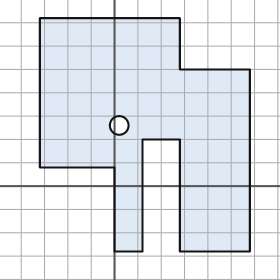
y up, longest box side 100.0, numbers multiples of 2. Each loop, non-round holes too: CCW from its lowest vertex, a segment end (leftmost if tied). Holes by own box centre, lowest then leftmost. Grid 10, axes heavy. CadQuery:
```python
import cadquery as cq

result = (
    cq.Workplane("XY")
    .moveTo(0.0, -28.0)
    .lineTo(12.0, -28.0)
    .lineTo(12.0, 20.0)
    .lineTo(28.0, 20.0)
    .lineTo(28.0, -28.0)
    .lineTo(58.0, -28.0)
    .lineTo(58.0, 50.0)
    .lineTo(28.0, 50.0)
    .lineTo(28.0, 72.0)
    .lineTo(-32.0, 72.0)
    .lineTo(-32.0, 8.0)
    .lineTo(0.0, 8.0)
    .close()
    .moveTo(2.0, 26.0)
    .circle(4.0)
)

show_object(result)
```